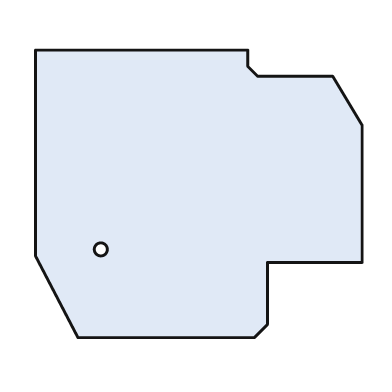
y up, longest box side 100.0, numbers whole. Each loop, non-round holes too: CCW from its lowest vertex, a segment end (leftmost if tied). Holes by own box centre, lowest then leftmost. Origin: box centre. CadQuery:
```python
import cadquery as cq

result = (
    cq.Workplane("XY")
    .moveTo(-37.0, -44.0)
    .lineTo(17.0, -44.0)
    .lineTo(21.0, -40.0)
    .lineTo(21.0, -21.0)
    .lineTo(50.0, -21.0)
    .lineTo(50.0, 21.0)
    .lineTo(41.0, 36.0)
    .lineTo(18.0, 36.0)
    .lineTo(15.0, 39.0)
    .lineTo(15.0, 44.0)
    .lineTo(-50.0, 44.0)
    .lineTo(-50.0, -19.0)
    .close()
    .moveTo(-30.0, -17.0)
    .circle(2.0)
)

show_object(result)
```